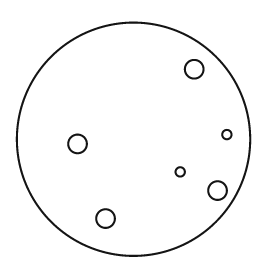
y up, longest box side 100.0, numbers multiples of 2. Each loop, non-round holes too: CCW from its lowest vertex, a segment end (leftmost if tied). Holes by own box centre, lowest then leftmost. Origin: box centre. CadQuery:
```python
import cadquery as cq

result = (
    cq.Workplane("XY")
    .moveTo(0.0, 0.0)
    .circle(50.0)
    .moveTo(-12.0, -34.0)
    .circle(4.0)
    .moveTo(36.0, -22.0)
    .circle(4.0)
    .moveTo(20.0, -14.0)
    .circle(2.0)
    .moveTo(-24.0, -2.0)
    .circle(4.0)
    .moveTo(40.0, 2.0)
    .circle(2.0)
    .moveTo(26.0, 30.0)
    .circle(4.0)
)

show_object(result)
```